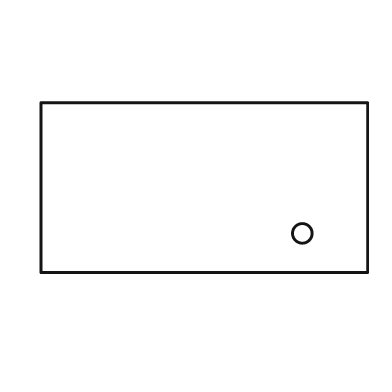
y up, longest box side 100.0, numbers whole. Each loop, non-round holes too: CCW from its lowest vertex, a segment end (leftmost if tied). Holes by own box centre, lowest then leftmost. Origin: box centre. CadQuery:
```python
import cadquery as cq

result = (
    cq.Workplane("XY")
    .moveTo(-50.0, -26.0)
    .lineTo(50.0, -26.0)
    .lineTo(50.0, 26.0)
    .lineTo(-50.0, 26.0)
    .close()
    .moveTo(30.0, -14.0)
    .circle(3.0)
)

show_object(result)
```